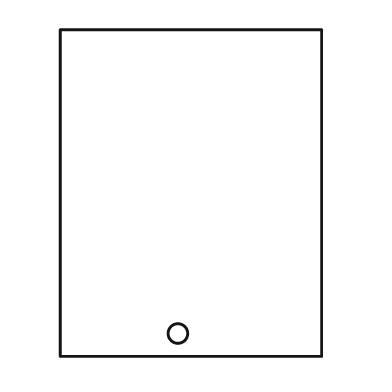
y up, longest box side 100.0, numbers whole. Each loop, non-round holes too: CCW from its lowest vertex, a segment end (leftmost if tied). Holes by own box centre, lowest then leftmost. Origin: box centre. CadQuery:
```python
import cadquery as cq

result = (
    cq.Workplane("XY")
    .moveTo(-40.0, -50.0)
    .lineTo(40.0, -50.0)
    .lineTo(40.0, 50.0)
    .lineTo(-40.0, 50.0)
    .close()
    .moveTo(-4.0, -43.0)
    .circle(3.0)
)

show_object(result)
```